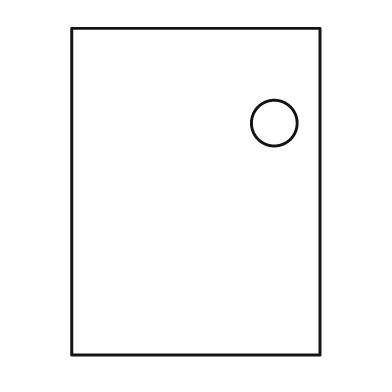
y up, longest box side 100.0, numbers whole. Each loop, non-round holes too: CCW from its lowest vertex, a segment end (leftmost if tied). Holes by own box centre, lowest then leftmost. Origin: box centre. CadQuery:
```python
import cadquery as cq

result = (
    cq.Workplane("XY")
    .moveTo(-38.0, -50.0)
    .lineTo(38.0, -50.0)
    .lineTo(38.0, 50.0)
    .lineTo(-38.0, 50.0)
    .close()
    .moveTo(24.0, 21.0)
    .circle(7.0)
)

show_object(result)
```